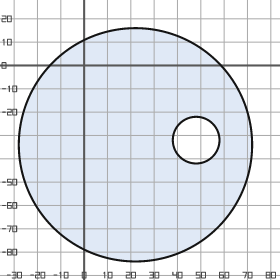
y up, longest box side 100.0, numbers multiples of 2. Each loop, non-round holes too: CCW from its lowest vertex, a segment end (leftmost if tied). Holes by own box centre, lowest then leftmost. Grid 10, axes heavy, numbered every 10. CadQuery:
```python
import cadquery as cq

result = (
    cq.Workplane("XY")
    .moveTo(22.0, -34.0)
    .circle(50.0)
    .moveTo(48.0, -32.0)
    .circle(10.0)
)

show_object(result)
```